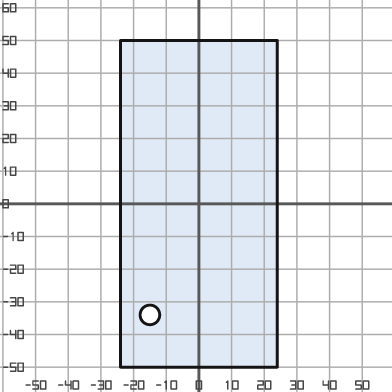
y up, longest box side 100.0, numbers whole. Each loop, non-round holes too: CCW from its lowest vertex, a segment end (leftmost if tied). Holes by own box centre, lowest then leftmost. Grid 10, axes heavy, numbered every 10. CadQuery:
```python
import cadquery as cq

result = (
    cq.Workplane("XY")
    .moveTo(-24.0, -50.0)
    .lineTo(24.0, -50.0)
    .lineTo(24.0, 50.0)
    .lineTo(-24.0, 50.0)
    .close()
    .moveTo(-15.0, -34.0)
    .circle(3.0)
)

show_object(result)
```